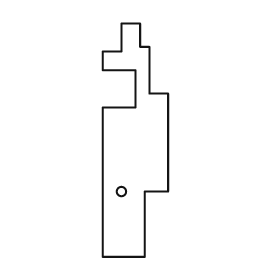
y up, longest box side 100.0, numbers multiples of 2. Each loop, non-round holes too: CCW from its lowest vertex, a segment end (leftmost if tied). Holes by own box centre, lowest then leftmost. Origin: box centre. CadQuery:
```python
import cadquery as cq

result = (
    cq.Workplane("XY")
    .moveTo(-14.0, -50.0)
    .lineTo(4.0, -50.0)
    .lineTo(4.0, -22.0)
    .lineTo(14.0, -22.0)
    .lineTo(14.0, 20.0)
    .lineTo(6.0, 20.0)
    .lineTo(6.0, 40.0)
    .lineTo(2.0, 40.0)
    .lineTo(2.0, 50.0)
    .lineTo(-6.0, 50.0)
    .lineTo(-6.0, 38.0)
    .lineTo(-14.0, 38.0)
    .lineTo(-14.0, 30.0)
    .lineTo(0.0, 30.0)
    .lineTo(0.0, 14.0)
    .lineTo(-14.0, 14.0)
    .close()
    .moveTo(-6.0, -22.0)
    .circle(2.0)
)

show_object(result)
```